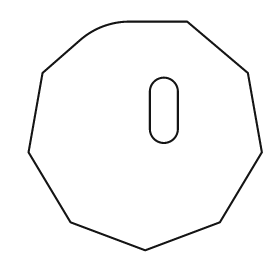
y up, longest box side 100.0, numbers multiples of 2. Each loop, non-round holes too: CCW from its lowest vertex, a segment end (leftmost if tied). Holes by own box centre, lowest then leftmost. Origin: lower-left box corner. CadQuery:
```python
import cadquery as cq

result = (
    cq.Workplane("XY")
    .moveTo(50.0, 0.0)
    .lineTo(82.0, 12.0)
    .lineTo(100.0, 42.0)
    .lineTo(94.0, 76.0)
    .lineTo(68.0, 98.0)
    .lineTo(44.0, 98.0)
    .threePointArc((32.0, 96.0), (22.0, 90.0))
    .lineTo(6.0, 76.0)
    .lineTo(0.0, 42.0)
    .lineTo(18.0, 12.0)
    .close()
    .moveTo(52.0, 52.0)
    .threePointArc((58.0, 46.0), (64.0, 52.0))
    .lineTo(64.0, 68.0)
    .threePointArc((58.0, 74.0), (52.0, 68.0))
    .close()
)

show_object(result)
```